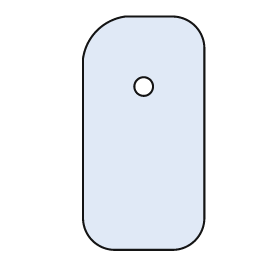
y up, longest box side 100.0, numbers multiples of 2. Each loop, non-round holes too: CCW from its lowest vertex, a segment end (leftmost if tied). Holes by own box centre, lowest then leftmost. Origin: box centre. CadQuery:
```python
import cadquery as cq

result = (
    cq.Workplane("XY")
    .moveTo(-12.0, -50.0)
    .lineTo(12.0, -50.0)
    .threePointArc((22.0, -46.0), (26.0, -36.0))
    .lineTo(26.0, 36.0)
    .threePointArc((22.0, 46.0), (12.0, 50.0))
    .lineTo(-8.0, 50.0)
    .threePointArc((-20.0, 44.0), (-26.0, 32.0))
    .lineTo(-26.0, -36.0)
    .threePointArc((-22.0, -46.0), (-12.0, -50.0))
    .close()
    .moveTo(0.0, 20.0)
    .circle(4.0)
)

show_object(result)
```